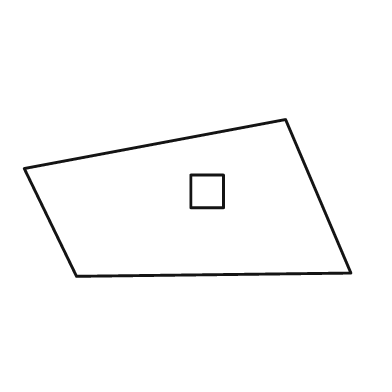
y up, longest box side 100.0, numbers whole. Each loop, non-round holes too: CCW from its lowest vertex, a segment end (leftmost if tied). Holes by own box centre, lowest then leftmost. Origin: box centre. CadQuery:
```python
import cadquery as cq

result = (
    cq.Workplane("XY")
    .moveTo(-34.0, -24.0)
    .lineTo(50.0, -23.0)
    .lineTo(30.0, 24.0)
    .lineTo(-50.0, 9.0)
    .close()
    .moveTo(1.0, -3.0)
    .lineTo(11.0, -3.0)
    .lineTo(11.0, 7.0)
    .lineTo(1.0, 7.0)
    .close()
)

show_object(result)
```